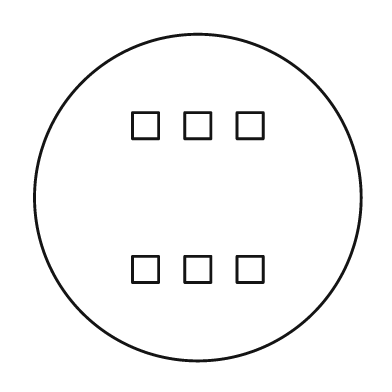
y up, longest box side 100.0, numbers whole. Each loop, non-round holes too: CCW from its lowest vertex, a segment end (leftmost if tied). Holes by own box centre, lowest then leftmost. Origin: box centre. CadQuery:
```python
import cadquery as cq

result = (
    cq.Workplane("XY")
    .moveTo(0.0, 0.0)
    .circle(50.0)
    .moveTo(-20.0, -26.0)
    .lineTo(-12.0, -26.0)
    .lineTo(-12.0, -18.0)
    .lineTo(-20.0, -18.0)
    .close()
    .moveTo(-4.0, -26.0)
    .lineTo(4.0, -26.0)
    .lineTo(4.0, -18.0)
    .lineTo(-4.0, -18.0)
    .close()
    .moveTo(12.0, -26.0)
    .lineTo(20.0, -26.0)
    .lineTo(20.0, -18.0)
    .lineTo(12.0, -18.0)
    .close()
    .moveTo(-20.0, 18.0)
    .lineTo(-12.0, 18.0)
    .lineTo(-12.0, 26.0)
    .lineTo(-20.0, 26.0)
    .close()
    .moveTo(-4.0, 18.0)
    .lineTo(4.0, 18.0)
    .lineTo(4.0, 26.0)
    .lineTo(-4.0, 26.0)
    .close()
    .moveTo(12.0, 18.0)
    .lineTo(20.0, 18.0)
    .lineTo(20.0, 26.0)
    .lineTo(12.0, 26.0)
    .close()
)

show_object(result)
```